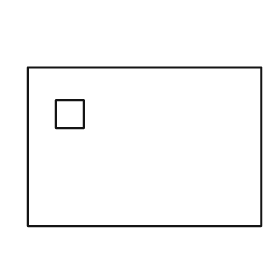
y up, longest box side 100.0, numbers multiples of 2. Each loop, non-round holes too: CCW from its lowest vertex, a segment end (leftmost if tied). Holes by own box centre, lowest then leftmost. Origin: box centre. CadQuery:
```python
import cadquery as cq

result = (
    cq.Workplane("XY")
    .moveTo(-50.0, -34.0)
    .lineTo(50.0, -34.0)
    .lineTo(50.0, 34.0)
    .lineTo(-50.0, 34.0)
    .close()
    .moveTo(-38.0, 8.0)
    .lineTo(-26.0, 8.0)
    .lineTo(-26.0, 20.0)
    .lineTo(-38.0, 20.0)
    .close()
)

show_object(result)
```